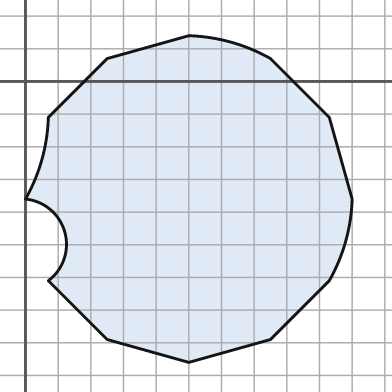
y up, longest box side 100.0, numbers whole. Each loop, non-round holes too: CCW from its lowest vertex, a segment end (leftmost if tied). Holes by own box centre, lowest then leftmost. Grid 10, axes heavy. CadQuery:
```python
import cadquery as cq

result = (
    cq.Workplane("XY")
    .moveTo(50.0, -86.0)
    .lineTo(75.0, -79.0)
    .lineTo(93.0, -61.0)
    .threePointArc((98.0, -49.0), (100.0, -36.0))
    .lineTo(93.0, -11.0)
    .lineTo(75.0, 7.0)
    .threePointArc((63.0, 12.0), (50.0, 14.0))
    .lineTo(25.0, 7.0)
    .lineTo(7.0, -11.0)
    .threePointArc((5.0, -24.0), (0.0, -36.0))
    .threePointArc((12.0, -46.0), (7.0, -61.0))
    .lineTo(25.0, -79.0)
    .close()
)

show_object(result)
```